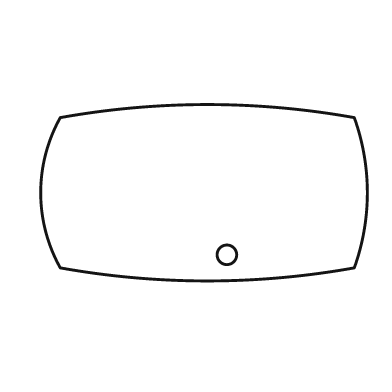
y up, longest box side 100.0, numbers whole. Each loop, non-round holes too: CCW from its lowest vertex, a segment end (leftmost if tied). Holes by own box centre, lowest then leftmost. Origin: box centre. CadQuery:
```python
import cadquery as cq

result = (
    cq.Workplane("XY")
    .moveTo(-44.0, -23.0)
    .threePointArc((1.0, -27.0), (46.0, -23.0))
    .threePointArc((50.0, 0.0), (46.0, 23.0))
    .threePointArc((1.0, 27.0), (-44.0, 23.0))
    .threePointArc((-50.0, 0.0), (-44.0, -23.0))
    .close()
    .moveTo(7.0, -19.0)
    .circle(3.0)
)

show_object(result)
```